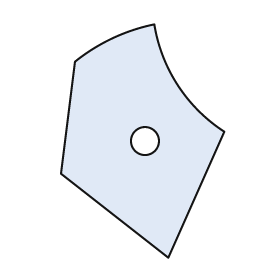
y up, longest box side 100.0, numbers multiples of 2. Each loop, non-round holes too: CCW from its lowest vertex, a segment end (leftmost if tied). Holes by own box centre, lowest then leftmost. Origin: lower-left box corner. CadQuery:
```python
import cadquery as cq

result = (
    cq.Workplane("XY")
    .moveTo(46.0, 0.0)
    .lineTo(70.0, 54.0)
    .threePointArc((50.0, 74.0), (40.0, 100.0))
    .threePointArc((22.0, 94.0), (6.0, 84.0))
    .lineTo(0.0, 36.0)
    .close()
    .moveTo(36.0, 50.0)
    .circle(6.0)
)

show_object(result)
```